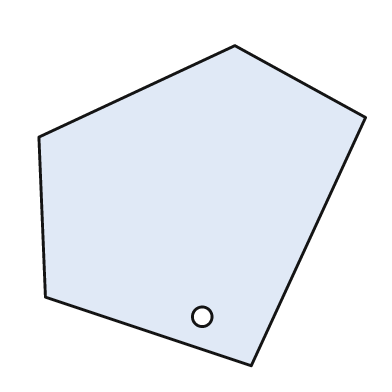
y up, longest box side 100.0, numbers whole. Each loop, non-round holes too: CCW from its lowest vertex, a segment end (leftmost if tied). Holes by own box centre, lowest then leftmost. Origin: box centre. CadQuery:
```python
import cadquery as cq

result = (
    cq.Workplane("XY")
    .moveTo(15.0, -49.0)
    .lineTo(50.0, 27.0)
    .lineTo(10.0, 49.0)
    .lineTo(-50.0, 21.0)
    .lineTo(-48.0, -28.0)
    .close()
    .moveTo(0.0, -34.0)
    .circle(3.0)
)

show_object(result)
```